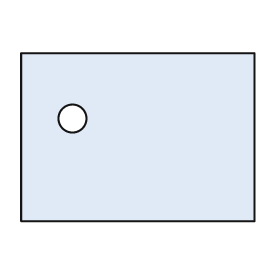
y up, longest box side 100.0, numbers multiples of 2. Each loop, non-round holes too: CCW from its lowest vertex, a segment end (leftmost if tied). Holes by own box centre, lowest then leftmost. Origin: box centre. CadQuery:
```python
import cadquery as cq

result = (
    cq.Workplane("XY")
    .moveTo(-50.0, -36.0)
    .lineTo(50.0, -36.0)
    .lineTo(50.0, 36.0)
    .lineTo(-50.0, 36.0)
    .close()
    .moveTo(-28.0, 8.0)
    .circle(6.0)
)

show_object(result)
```